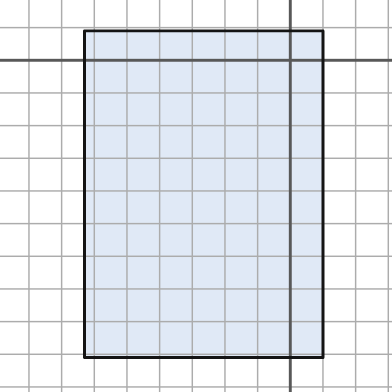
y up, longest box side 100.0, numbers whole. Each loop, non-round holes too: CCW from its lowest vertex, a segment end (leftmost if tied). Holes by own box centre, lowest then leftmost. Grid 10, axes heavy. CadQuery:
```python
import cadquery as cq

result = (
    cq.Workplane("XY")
    .moveTo(-63.0, -91.0)
    .lineTo(10.0, -91.0)
    .lineTo(10.0, 9.0)
    .lineTo(-63.0, 9.0)
    .close()
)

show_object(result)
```